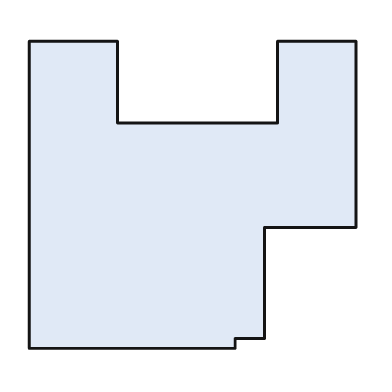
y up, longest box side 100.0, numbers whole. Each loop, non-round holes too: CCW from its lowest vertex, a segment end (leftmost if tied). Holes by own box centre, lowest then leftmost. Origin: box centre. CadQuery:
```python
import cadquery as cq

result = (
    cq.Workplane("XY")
    .moveTo(-50.0, -47.0)
    .lineTo(13.0, -47.0)
    .lineTo(13.0, -44.0)
    .lineTo(22.0, -44.0)
    .lineTo(22.0, -10.0)
    .lineTo(50.0, -10.0)
    .lineTo(50.0, 47.0)
    .lineTo(26.0, 47.0)
    .lineTo(26.0, 22.0)
    .lineTo(-23.0, 22.0)
    .lineTo(-23.0, 47.0)
    .lineTo(-50.0, 47.0)
    .close()
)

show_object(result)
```